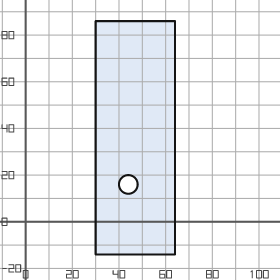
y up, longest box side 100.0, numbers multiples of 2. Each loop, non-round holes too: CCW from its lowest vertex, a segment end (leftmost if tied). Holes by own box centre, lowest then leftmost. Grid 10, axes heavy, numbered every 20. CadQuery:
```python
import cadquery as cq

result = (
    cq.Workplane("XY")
    .moveTo(30.0, -14.0)
    .lineTo(64.0, -14.0)
    .lineTo(64.0, 86.0)
    .lineTo(30.0, 86.0)
    .close()
    .moveTo(44.0, 16.0)
    .circle(4.0)
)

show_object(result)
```